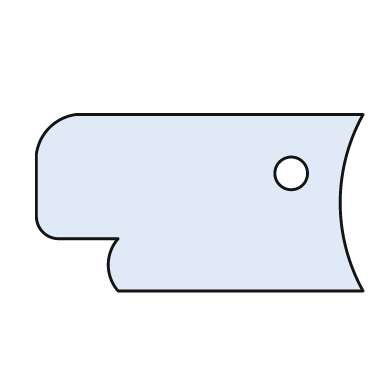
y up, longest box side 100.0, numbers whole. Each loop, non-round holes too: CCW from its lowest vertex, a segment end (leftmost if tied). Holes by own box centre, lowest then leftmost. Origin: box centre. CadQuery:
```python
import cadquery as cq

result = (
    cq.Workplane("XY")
    .moveTo(-25.0, -27.0)
    .lineTo(50.0, -27.0)
    .threePointArc((43.0, 0.0), (50.0, 27.0))
    .lineTo(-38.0, 27.0)
    .threePointArc((-46.0, 23.0), (-50.0, 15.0))
    .lineTo(-50.0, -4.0)
    .threePointArc((-48.0, -9.0), (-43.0, -11.0))
    .lineTo(-25.0, -11.0)
    .threePointArc((-28.0, -19.0), (-25.0, -27.0))
    .close()
    .moveTo(28.0, 9.0)
    .circle(5.0)
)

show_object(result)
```